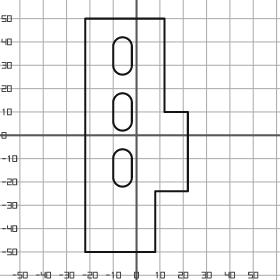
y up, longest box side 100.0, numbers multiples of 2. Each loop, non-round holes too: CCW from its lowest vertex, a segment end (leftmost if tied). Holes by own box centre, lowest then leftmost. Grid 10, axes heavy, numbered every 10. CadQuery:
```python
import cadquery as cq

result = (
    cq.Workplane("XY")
    .moveTo(-22.0, -50.0)
    .lineTo(8.0, -50.0)
    .lineTo(8.0, -24.0)
    .lineTo(22.0, -24.0)
    .lineTo(22.0, 10.0)
    .lineTo(12.0, 10.0)
    .lineTo(12.0, 50.0)
    .lineTo(-22.0, 50.0)
    .close()
    .moveTo(-10.0, -18.0)
    .threePointArc((-6.0, -22.0), (-2.0, -18.0))
    .lineTo(-2.0, -10.0)
    .threePointArc((-6.0, -6.0), (-10.0, -10.0))
    .close()
    .moveTo(-10.0, 6.0)
    .threePointArc((-6.0, 2.0), (-2.0, 6.0))
    .lineTo(-2.0, 14.0)
    .threePointArc((-6.0, 18.0), (-10.0, 14.0))
    .close()
    .moveTo(-10.0, 30.0)
    .threePointArc((-6.0, 26.0), (-2.0, 30.0))
    .lineTo(-2.0, 38.0)
    .threePointArc((-6.0, 42.0), (-10.0, 38.0))
    .close()
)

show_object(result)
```